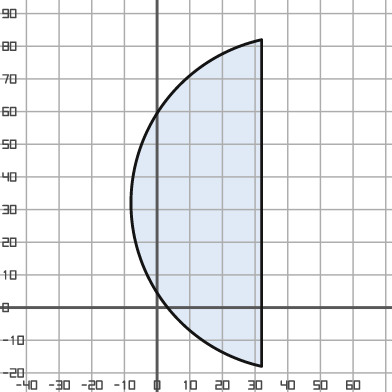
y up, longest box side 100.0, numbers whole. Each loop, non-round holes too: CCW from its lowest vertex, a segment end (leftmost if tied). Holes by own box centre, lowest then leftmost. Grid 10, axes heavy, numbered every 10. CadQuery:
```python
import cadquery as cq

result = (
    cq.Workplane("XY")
    .moveTo(32.0, -18.0)
    .lineTo(32.0, 82.0)
    .threePointArc((-8.0, 32.0), (32.0, -18.0))
    .close()
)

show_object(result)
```